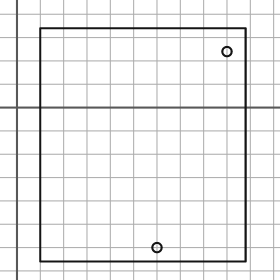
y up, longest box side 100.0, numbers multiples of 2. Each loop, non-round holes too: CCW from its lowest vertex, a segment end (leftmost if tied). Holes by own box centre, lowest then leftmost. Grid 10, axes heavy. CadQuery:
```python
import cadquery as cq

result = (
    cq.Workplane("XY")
    .moveTo(10.0, -66.0)
    .lineTo(98.0, -66.0)
    .lineTo(98.0, 34.0)
    .lineTo(10.0, 34.0)
    .close()
    .moveTo(60.0, -60.0)
    .circle(2.0)
    .moveTo(90.0, 24.0)
    .circle(2.0)
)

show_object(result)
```